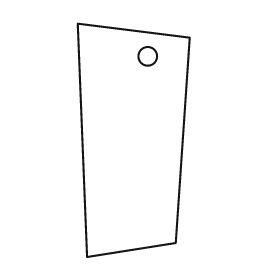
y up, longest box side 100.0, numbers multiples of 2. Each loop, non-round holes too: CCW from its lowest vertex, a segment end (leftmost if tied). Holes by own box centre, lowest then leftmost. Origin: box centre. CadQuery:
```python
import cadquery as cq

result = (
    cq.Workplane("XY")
    .moveTo(-20.0, -50.0)
    .lineTo(18.0, -44.0)
    .lineTo(24.0, 44.0)
    .lineTo(-24.0, 50.0)
    .close()
    .moveTo(6.0, 36.0)
    .circle(4.0)
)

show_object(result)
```